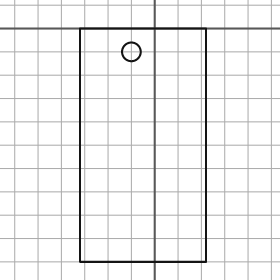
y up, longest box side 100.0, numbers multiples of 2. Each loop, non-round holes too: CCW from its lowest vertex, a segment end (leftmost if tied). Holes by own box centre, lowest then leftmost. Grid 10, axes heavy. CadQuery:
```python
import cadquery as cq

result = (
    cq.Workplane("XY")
    .moveTo(-32.0, -100.0)
    .lineTo(22.0, -100.0)
    .lineTo(22.0, 0.0)
    .lineTo(-32.0, 0.0)
    .close()
    .moveTo(-10.0, -10.0)
    .circle(4.0)
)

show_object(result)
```